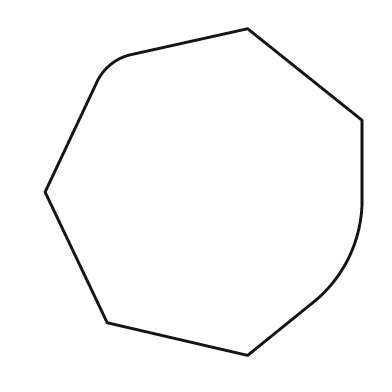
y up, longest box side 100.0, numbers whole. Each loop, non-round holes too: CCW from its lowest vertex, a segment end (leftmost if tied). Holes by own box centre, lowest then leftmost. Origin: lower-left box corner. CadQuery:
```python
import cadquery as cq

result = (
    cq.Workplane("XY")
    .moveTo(62.0, 0.0)
    .lineTo(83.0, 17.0)
    .threePointArc((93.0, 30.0), (97.0, 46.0))
    .lineTo(97.0, 72.0)
    .lineTo(62.0, 100.0)
    .lineTo(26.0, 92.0)
    .threePointArc((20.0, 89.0), (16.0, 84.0))
    .lineTo(0.0, 50.0)
    .lineTo(19.0, 10.0)
    .close()
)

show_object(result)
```